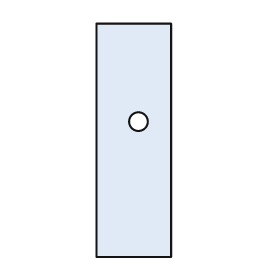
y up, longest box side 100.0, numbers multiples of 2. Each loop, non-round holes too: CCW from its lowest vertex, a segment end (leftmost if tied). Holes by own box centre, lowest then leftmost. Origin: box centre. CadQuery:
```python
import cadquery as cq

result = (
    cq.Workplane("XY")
    .moveTo(-16.0, -50.0)
    .lineTo(16.0, -50.0)
    .lineTo(16.0, 50.0)
    .lineTo(-16.0, 50.0)
    .close()
    .moveTo(2.0, 8.0)
    .circle(4.0)
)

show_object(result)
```